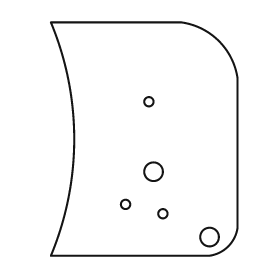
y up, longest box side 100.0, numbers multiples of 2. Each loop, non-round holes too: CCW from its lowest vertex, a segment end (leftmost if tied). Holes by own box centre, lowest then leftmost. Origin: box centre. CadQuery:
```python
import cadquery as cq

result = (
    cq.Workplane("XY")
    .moveTo(-40.0, -50.0)
    .lineTo(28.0, -50.0)
    .threePointArc((36.0, -46.0), (40.0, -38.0))
    .lineTo(40.0, 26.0)
    .threePointArc((32.0, 42.0), (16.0, 50.0))
    .lineTo(-40.0, 50.0)
    .threePointArc((-30.0, 0.0), (-40.0, -50.0))
    .close()
    .moveTo(28.0, -42.0)
    .circle(4.0)
    .moveTo(8.0, -32.0)
    .circle(2.0)
    .moveTo(-8.0, -28.0)
    .circle(2.0)
    .moveTo(4.0, -14.0)
    .circle(4.0)
    .moveTo(2.0, 16.0)
    .circle(2.0)
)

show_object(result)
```